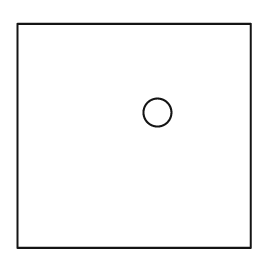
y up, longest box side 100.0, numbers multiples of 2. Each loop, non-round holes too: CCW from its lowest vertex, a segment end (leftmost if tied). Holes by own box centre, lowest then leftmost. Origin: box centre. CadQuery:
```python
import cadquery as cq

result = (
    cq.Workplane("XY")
    .moveTo(-50.0, -48.0)
    .lineTo(50.0, -48.0)
    .lineTo(50.0, 48.0)
    .lineTo(-50.0, 48.0)
    .close()
    .moveTo(10.0, 10.0)
    .circle(6.0)
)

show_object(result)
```